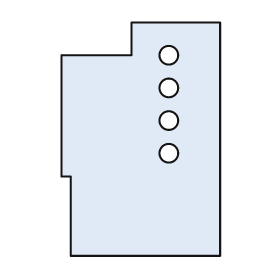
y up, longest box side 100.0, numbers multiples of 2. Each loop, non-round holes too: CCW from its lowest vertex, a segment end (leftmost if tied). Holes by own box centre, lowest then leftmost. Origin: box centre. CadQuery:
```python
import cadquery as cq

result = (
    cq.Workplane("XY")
    .moveTo(-30.0, -50.0)
    .lineTo(34.0, -50.0)
    .lineTo(34.0, 50.0)
    .lineTo(-4.0, 50.0)
    .lineTo(-4.0, 36.0)
    .lineTo(-34.0, 36.0)
    .lineTo(-34.0, -16.0)
    .lineTo(-30.0, -16.0)
    .close()
    .moveTo(12.0, -6.0)
    .circle(4.0)
    .moveTo(12.0, 8.0)
    .circle(4.0)
    .moveTo(12.0, 22.0)
    .circle(4.0)
    .moveTo(12.0, 36.0)
    .circle(4.0)
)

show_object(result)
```